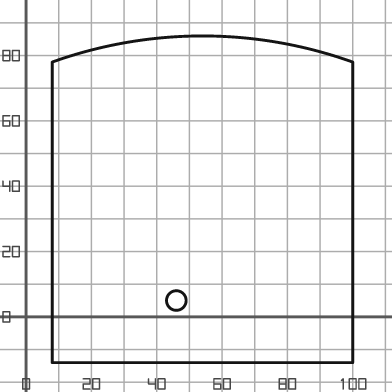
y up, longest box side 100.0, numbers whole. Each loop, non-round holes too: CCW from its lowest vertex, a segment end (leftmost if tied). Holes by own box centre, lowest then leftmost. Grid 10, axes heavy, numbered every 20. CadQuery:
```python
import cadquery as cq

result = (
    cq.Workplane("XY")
    .moveTo(8.0, -14.0)
    .lineTo(100.0, -14.0)
    .lineTo(100.0, 78.0)
    .threePointArc((54.0, 86.0), (8.0, 78.0))
    .close()
    .moveTo(46.0, 5.0)
    .circle(3.0)
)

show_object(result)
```